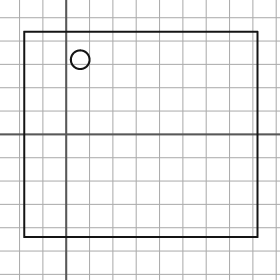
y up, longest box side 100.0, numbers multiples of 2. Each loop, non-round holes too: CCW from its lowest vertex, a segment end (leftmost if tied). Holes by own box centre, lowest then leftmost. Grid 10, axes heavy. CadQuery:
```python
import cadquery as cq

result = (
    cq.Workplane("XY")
    .moveTo(-18.0, -44.0)
    .lineTo(82.0, -44.0)
    .lineTo(82.0, 44.0)
    .lineTo(-18.0, 44.0)
    .close()
    .moveTo(6.0, 32.0)
    .circle(4.0)
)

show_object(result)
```